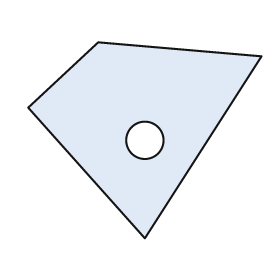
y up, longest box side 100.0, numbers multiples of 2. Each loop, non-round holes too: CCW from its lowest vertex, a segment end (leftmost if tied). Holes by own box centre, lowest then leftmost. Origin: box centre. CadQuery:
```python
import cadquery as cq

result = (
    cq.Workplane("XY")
    .moveTo(0.0, -42.0)
    .lineTo(50.0, 36.0)
    .lineTo(-20.0, 42.0)
    .lineTo(-50.0, 14.0)
    .close()
    .moveTo(0.0, 0.0)
    .circle(8.0)
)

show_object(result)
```